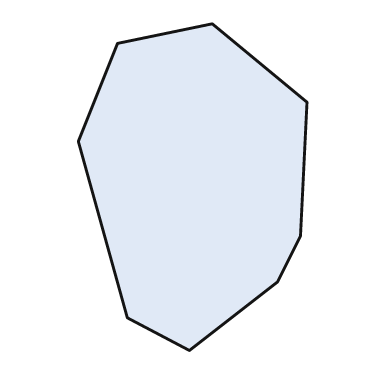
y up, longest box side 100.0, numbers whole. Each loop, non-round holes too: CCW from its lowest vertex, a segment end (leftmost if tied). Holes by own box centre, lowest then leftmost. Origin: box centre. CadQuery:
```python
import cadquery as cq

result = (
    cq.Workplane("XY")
    .moveTo(-1.0, -50.0)
    .lineTo(26.0, -29.0)
    .lineTo(33.0, -15.0)
    .lineTo(35.0, 26.0)
    .lineTo(6.0, 50.0)
    .lineTo(-23.0, 44.0)
    .lineTo(-35.0, 14.0)
    .lineTo(-20.0, -40.0)
    .close()
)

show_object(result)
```